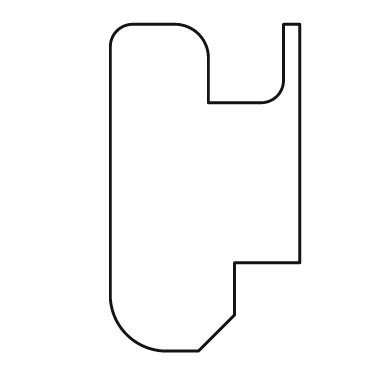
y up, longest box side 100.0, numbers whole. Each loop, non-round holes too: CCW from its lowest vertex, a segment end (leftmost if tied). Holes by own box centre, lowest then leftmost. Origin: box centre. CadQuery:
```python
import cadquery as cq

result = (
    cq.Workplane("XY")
    .moveTo(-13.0, -50.0)
    .lineTo(-2.0, -50.0)
    .lineTo(9.0, -39.0)
    .lineTo(9.0, -23.0)
    .lineTo(29.0, -23.0)
    .lineTo(29.0, 50.0)
    .lineTo(24.0, 50.0)
    .lineTo(24.0, 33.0)
    .threePointArc((22.0, 28.0), (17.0, 26.0))
    .lineTo(1.0, 26.0)
    .lineTo(1.0, 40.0)
    .threePointArc((-2.0, 47.0), (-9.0, 50.0))
    .lineTo(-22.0, 50.0)
    .threePointArc((-27.0, 48.0), (-29.0, 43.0))
    .lineTo(-29.0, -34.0)
    .threePointArc((-24.0, -45.0), (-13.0, -50.0))
    .close()
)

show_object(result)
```